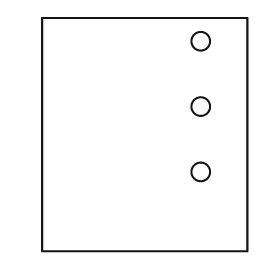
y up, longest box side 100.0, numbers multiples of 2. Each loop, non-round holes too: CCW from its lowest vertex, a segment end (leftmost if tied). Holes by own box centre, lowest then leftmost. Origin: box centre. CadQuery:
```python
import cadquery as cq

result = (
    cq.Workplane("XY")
    .moveTo(-44.0, -50.0)
    .lineTo(44.0, -50.0)
    .lineTo(44.0, 50.0)
    .lineTo(-44.0, 50.0)
    .close()
    .moveTo(24.0, -16.0)
    .circle(4.0)
    .moveTo(24.0, 12.0)
    .circle(4.0)
    .moveTo(24.0, 40.0)
    .circle(4.0)
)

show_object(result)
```